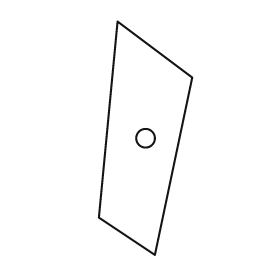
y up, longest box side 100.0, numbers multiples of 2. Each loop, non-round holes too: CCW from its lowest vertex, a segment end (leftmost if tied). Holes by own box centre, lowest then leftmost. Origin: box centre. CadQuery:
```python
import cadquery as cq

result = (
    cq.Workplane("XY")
    .moveTo(4.0, -50.0)
    .lineTo(20.0, 26.0)
    .lineTo(-12.0, 50.0)
    .lineTo(-20.0, -34.0)
    .close()
    .moveTo(0.0, 0.0)
    .circle(4.0)
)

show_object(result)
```